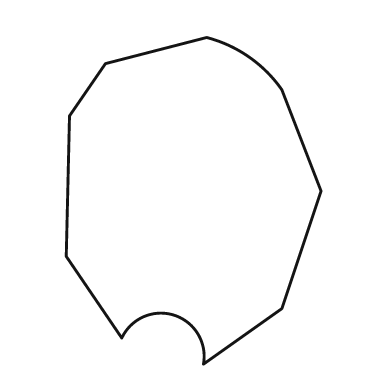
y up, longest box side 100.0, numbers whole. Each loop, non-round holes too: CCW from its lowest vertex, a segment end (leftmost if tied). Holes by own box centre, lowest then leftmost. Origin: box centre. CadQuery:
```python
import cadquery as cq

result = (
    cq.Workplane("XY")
    .moveTo(3.0, -50.0)
    .lineTo(27.0, -33.0)
    .lineTo(39.0, 3.0)
    .lineTo(27.0, 34.0)
    .threePointArc((17.0, 44.0), (4.0, 50.0))
    .lineTo(-27.0, 42.0)
    .lineTo(-38.0, 26.0)
    .lineTo(-39.0, -17.0)
    .lineTo(-22.0, -42.0)
    .threePointArc((-6.0, -35.0), (3.0, -50.0))
    .close()
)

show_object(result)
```